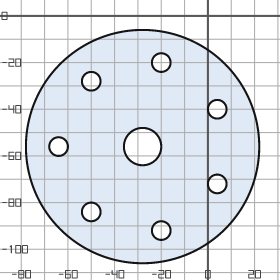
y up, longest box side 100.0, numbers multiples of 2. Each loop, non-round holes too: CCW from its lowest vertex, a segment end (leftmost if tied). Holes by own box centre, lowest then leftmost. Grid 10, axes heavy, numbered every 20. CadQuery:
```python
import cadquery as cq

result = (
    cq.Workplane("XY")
    .moveTo(-28.0, -56.0)
    .circle(50.0)
    .moveTo(-20.0, -92.0)
    .circle(4.0)
    .moveTo(-50.0, -84.0)
    .circle(4.0)
    .moveTo(4.0, -72.0)
    .circle(4.0)
    .moveTo(-64.0, -56.0)
    .circle(4.0)
    .moveTo(-28.0, -56.0)
    .circle(8.0)
    .moveTo(4.0, -40.0)
    .circle(4.0)
    .moveTo(-50.0, -28.0)
    .circle(4.0)
    .moveTo(-20.0, -20.0)
    .circle(4.0)
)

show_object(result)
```